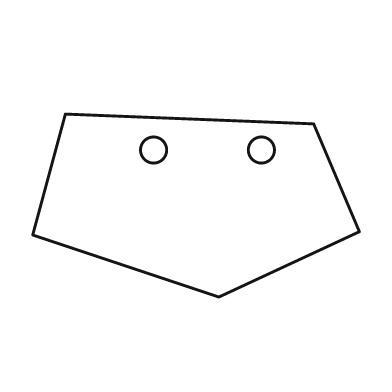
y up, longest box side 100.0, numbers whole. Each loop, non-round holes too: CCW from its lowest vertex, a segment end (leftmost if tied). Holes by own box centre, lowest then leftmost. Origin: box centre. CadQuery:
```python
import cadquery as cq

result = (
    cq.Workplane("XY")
    .moveTo(7.0, -28.0)
    .lineTo(50.0, -8.0)
    .lineTo(36.0, 25.0)
    .lineTo(-40.0, 28.0)
    .lineTo(-50.0, -9.0)
    .close()
    .moveTo(-13.0, 17.0)
    .circle(4.0)
    .moveTo(20.0, 17.0)
    .circle(4.0)
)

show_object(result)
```